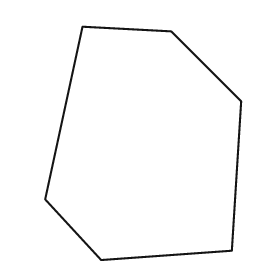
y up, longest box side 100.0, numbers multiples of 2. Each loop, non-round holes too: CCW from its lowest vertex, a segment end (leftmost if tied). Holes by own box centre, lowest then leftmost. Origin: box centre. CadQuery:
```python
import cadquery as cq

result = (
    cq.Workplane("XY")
    .moveTo(-18.0, -50.0)
    .lineTo(38.0, -46.0)
    .lineTo(42.0, 18.0)
    .lineTo(12.0, 48.0)
    .lineTo(-26.0, 50.0)
    .lineTo(-42.0, -24.0)
    .close()
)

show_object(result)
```